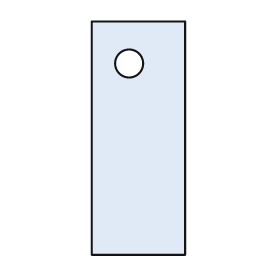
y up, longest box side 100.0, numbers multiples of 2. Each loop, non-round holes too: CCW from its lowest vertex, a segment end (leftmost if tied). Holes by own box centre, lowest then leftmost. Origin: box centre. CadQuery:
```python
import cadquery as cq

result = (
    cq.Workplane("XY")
    .moveTo(-20.0, -50.0)
    .lineTo(20.0, -50.0)
    .lineTo(20.0, 50.0)
    .lineTo(-20.0, 50.0)
    .close()
    .moveTo(-4.0, 32.0)
    .circle(6.0)
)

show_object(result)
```